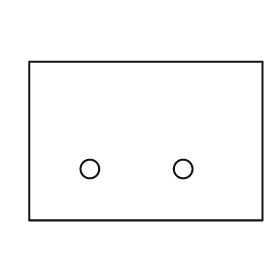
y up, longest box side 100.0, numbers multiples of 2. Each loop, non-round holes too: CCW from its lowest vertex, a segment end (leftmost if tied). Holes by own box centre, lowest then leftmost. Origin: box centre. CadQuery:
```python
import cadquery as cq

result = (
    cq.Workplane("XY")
    .moveTo(-50.0, -34.0)
    .lineTo(50.0, -34.0)
    .lineTo(50.0, 34.0)
    .lineTo(-50.0, 34.0)
    .close()
    .moveTo(-24.0, -12.0)
    .circle(4.0)
    .moveTo(16.0, -12.0)
    .circle(4.0)
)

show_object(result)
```